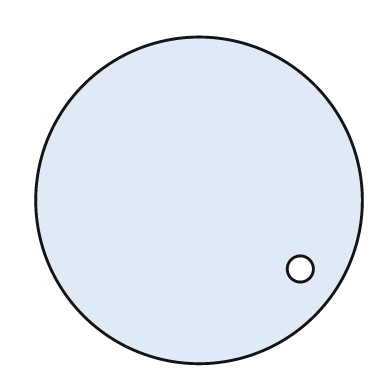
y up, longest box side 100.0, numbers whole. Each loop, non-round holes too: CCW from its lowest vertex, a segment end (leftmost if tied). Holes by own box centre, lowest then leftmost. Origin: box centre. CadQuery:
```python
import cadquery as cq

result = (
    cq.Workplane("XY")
    .moveTo(0.0, 0.0)
    .circle(50.0)
    .moveTo(31.0, -21.0)
    .circle(4.0)
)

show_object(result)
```